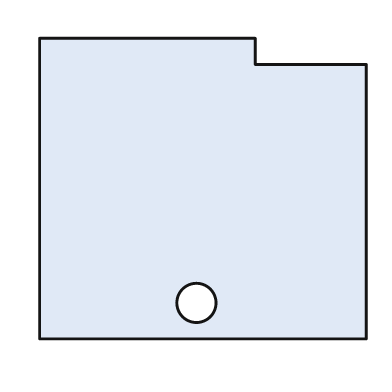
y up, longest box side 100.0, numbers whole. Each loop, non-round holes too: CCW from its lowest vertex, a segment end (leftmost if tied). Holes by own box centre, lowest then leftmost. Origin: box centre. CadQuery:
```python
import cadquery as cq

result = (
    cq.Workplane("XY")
    .moveTo(-50.0, -46.0)
    .lineTo(50.0, -46.0)
    .lineTo(50.0, 38.0)
    .lineTo(16.0, 38.0)
    .lineTo(16.0, 46.0)
    .lineTo(-50.0, 46.0)
    .close()
    .moveTo(-2.0, -35.0)
    .circle(6.0)
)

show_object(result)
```